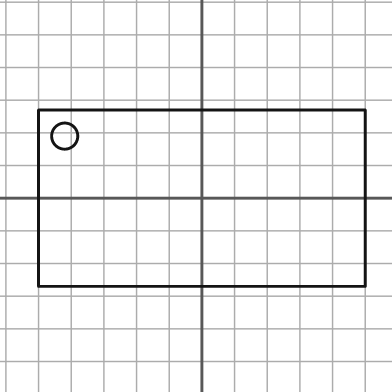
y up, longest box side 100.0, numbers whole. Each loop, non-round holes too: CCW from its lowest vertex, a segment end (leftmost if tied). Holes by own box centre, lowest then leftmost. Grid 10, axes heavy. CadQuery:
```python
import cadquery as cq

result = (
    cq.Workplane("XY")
    .moveTo(-50.0, -27.0)
    .lineTo(50.0, -27.0)
    .lineTo(50.0, 27.0)
    .lineTo(-50.0, 27.0)
    .close()
    .moveTo(-42.0, 19.0)
    .circle(4.0)
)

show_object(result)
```